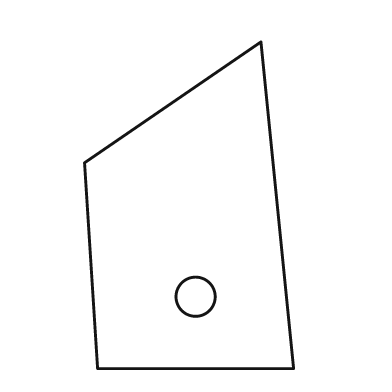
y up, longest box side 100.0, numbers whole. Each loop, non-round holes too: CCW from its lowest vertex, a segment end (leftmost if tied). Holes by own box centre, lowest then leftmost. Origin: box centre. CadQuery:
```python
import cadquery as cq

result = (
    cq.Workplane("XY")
    .moveTo(-28.0, -50.0)
    .lineTo(32.0, -50.0)
    .lineTo(22.0, 50.0)
    .lineTo(-32.0, 13.0)
    .close()
    .moveTo(2.0, -28.0)
    .circle(6.0)
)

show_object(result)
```